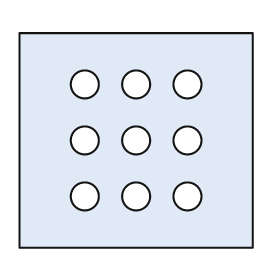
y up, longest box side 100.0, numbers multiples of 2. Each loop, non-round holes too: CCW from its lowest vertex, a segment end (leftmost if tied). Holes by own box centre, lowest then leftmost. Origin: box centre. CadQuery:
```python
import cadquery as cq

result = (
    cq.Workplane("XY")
    .moveTo(-50.0, -46.0)
    .lineTo(50.0, -46.0)
    .lineTo(50.0, 46.0)
    .lineTo(-50.0, 46.0)
    .close()
    .moveTo(-22.0, -24.0)
    .circle(6.0)
    .moveTo(0.0, -24.0)
    .circle(6.0)
    .moveTo(22.0, -24.0)
    .circle(6.0)
    .moveTo(-22.0, 0.0)
    .circle(6.0)
    .moveTo(0.0, 0.0)
    .circle(6.0)
    .moveTo(22.0, 0.0)
    .circle(6.0)
    .moveTo(-22.0, 24.0)
    .circle(6.0)
    .moveTo(0.0, 24.0)
    .circle(6.0)
    .moveTo(22.0, 24.0)
    .circle(6.0)
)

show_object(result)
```